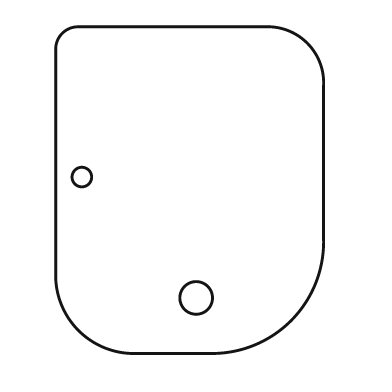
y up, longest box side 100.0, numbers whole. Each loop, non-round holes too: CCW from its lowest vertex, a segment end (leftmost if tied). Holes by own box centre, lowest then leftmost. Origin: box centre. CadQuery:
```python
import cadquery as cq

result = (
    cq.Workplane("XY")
    .moveTo(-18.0, -50.0)
    .lineTo(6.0, -50.0)
    .threePointArc((31.0, -40.0), (41.0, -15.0))
    .lineTo(41.0, 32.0)
    .threePointArc((36.0, 45.0), (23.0, 50.0))
    .lineTo(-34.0, 50.0)
    .threePointArc((-39.0, 48.0), (-41.0, 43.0))
    .lineTo(-41.0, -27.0)
    .threePointArc((-34.0, -43.0), (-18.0, -50.0))
    .close()
    .moveTo(2.0, -33.0)
    .circle(5.0)
    .moveTo(-33.0, 4.0)
    .circle(3.0)
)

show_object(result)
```